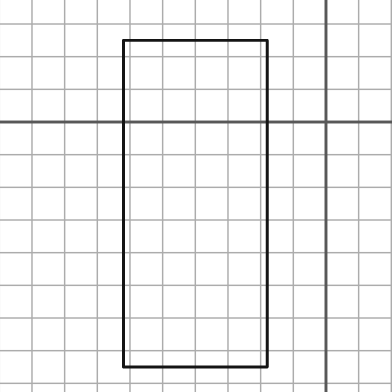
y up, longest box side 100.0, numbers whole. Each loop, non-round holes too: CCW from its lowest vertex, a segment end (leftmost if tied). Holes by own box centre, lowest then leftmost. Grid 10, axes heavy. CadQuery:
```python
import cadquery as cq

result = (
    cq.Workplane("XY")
    .moveTo(-62.0, -75.0)
    .lineTo(-18.0, -75.0)
    .lineTo(-18.0, 25.0)
    .lineTo(-62.0, 25.0)
    .close()
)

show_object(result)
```